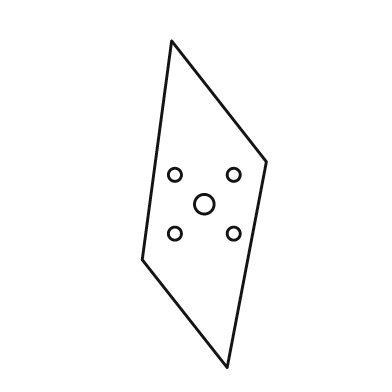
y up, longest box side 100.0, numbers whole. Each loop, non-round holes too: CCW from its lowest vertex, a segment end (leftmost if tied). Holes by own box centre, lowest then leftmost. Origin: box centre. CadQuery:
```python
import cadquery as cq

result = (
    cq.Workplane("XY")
    .moveTo(7.0, -50.0)
    .lineTo(19.0, 13.0)
    .lineTo(-10.0, 50.0)
    .lineTo(-19.0, -17.0)
    .close()
    .moveTo(-9.0, -9.0)
    .circle(2.0)
    .moveTo(9.0, -9.0)
    .circle(2.0)
    .moveTo(0.0, 0.0)
    .circle(3.0)
    .moveTo(-9.0, 9.0)
    .circle(2.0)
    .moveTo(9.0, 9.0)
    .circle(2.0)
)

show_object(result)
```